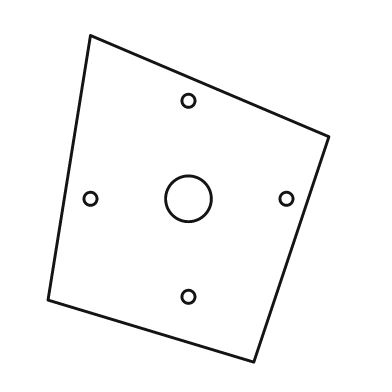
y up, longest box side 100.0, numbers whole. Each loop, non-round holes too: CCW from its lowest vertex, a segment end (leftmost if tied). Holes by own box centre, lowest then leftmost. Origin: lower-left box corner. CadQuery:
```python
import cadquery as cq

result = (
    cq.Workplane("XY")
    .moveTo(63.0, 0.0)
    .lineTo(86.0, 69.0)
    .lineTo(13.0, 100.0)
    .lineTo(0.0, 19.0)
    .close()
    .moveTo(43.0, 20.0)
    .circle(2.0)
    .moveTo(13.0, 50.0)
    .circle(2.0)
    .moveTo(43.0, 50.0)
    .circle(7.0)
    .moveTo(73.0, 50.0)
    .circle(2.0)
    .moveTo(43.0, 80.0)
    .circle(2.0)
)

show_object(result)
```